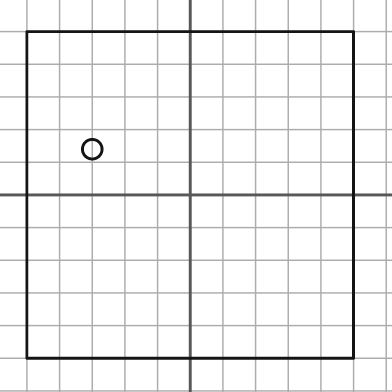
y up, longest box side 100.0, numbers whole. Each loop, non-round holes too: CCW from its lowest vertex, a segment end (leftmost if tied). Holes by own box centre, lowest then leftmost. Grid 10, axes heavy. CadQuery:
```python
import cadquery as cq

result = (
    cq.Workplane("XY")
    .moveTo(-50.0, -50.0)
    .lineTo(50.0, -50.0)
    .lineTo(50.0, 50.0)
    .lineTo(-50.0, 50.0)
    .close()
    .moveTo(-30.0, 14.0)
    .circle(3.0)
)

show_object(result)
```